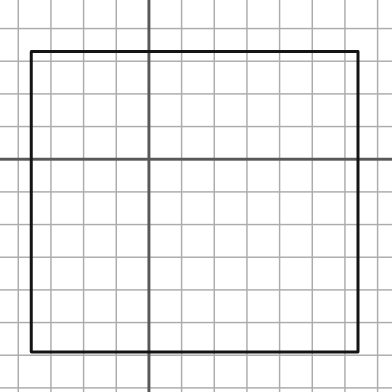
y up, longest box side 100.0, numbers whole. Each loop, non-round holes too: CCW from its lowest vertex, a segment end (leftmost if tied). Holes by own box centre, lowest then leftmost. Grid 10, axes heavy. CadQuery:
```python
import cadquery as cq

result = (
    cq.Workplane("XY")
    .moveTo(-36.0, -59.0)
    .lineTo(64.0, -59.0)
    .lineTo(64.0, 33.0)
    .lineTo(-36.0, 33.0)
    .close()
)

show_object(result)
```